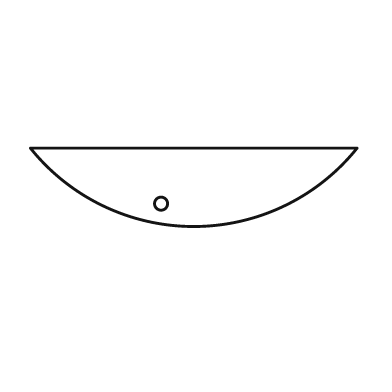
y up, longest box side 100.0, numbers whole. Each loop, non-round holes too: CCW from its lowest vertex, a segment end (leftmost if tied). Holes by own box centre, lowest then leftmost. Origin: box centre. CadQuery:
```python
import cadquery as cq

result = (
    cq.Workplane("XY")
    .moveTo(-50.0, 12.0)
    .threePointArc((0.0, -12.0), (50.0, 12.0))
    .close()
    .moveTo(-10.0, -5.0)
    .circle(2.0)
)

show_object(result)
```